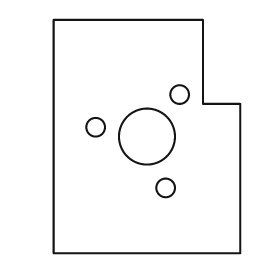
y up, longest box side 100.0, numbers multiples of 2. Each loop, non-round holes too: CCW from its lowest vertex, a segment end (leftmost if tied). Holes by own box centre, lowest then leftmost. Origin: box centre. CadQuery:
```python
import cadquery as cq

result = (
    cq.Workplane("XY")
    .moveTo(-40.0, -50.0)
    .lineTo(40.0, -50.0)
    .lineTo(40.0, 14.0)
    .lineTo(24.0, 14.0)
    .lineTo(24.0, 50.0)
    .lineTo(-40.0, 50.0)
    .close()
    .moveTo(8.0, -22.0)
    .circle(4.0)
    .moveTo(0.0, 0.0)
    .circle(12.0)
    .moveTo(-22.0, 4.0)
    .circle(4.0)
    .moveTo(14.0, 18.0)
    .circle(4.0)
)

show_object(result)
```